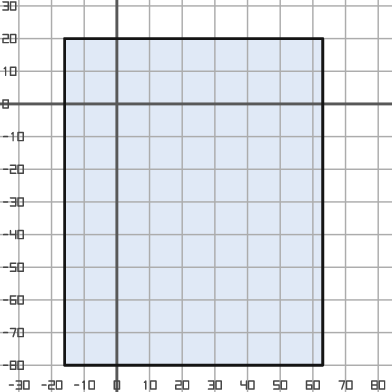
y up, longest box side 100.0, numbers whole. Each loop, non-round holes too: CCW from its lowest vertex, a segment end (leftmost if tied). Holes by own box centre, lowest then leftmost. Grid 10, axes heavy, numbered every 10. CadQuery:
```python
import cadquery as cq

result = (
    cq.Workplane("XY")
    .moveTo(-16.0, -80.0)
    .lineTo(63.0, -80.0)
    .lineTo(63.0, 20.0)
    .lineTo(-16.0, 20.0)
    .close()
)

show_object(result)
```